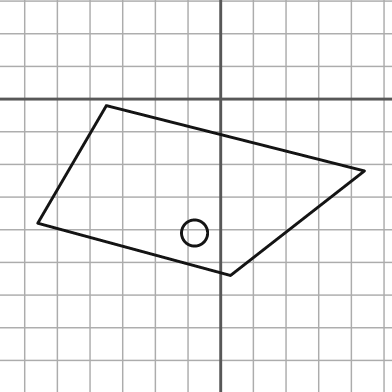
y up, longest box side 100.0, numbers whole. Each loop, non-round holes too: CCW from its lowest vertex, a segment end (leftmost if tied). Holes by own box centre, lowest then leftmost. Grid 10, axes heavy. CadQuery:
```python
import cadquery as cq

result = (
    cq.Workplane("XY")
    .moveTo(3.0, -54.0)
    .lineTo(44.0, -22.0)
    .lineTo(-35.0, -2.0)
    .lineTo(-56.0, -38.0)
    .close()
    .moveTo(-8.0, -41.0)
    .circle(4.0)
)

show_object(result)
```